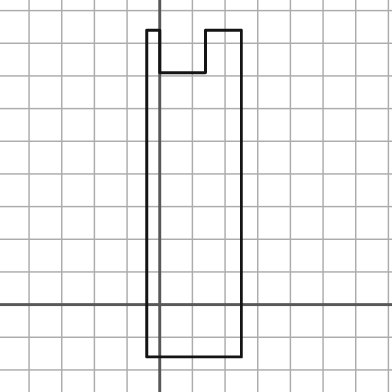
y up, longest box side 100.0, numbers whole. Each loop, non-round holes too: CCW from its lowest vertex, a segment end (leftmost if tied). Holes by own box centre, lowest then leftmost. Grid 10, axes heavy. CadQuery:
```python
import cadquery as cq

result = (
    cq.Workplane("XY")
    .moveTo(-4.0, -16.0)
    .lineTo(25.0, -16.0)
    .lineTo(25.0, 84.0)
    .lineTo(14.0, 84.0)
    .lineTo(14.0, 71.0)
    .lineTo(0.0, 71.0)
    .lineTo(0.0, 84.0)
    .lineTo(-4.0, 84.0)
    .close()
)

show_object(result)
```